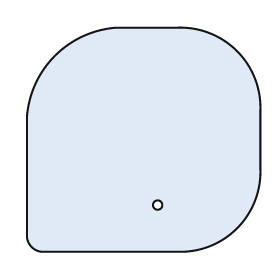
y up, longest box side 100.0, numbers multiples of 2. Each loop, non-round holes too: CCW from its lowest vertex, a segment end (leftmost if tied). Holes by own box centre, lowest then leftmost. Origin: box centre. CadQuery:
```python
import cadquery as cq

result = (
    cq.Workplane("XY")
    .moveTo(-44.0, -48.0)
    .lineTo(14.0, -48.0)
    .threePointArc((40.0, -38.0), (50.0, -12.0))
    .lineTo(50.0, 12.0)
    .threePointArc((40.0, 38.0), (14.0, 48.0))
    .lineTo(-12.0, 48.0)
    .threePointArc((-38.0, 36.0), (-50.0, 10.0))
    .lineTo(-50.0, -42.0)
    .threePointArc((-48.0, -46.0), (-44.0, -48.0))
    .close()
    .moveTo(6.0, -28.0)
    .circle(2.0)
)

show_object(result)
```